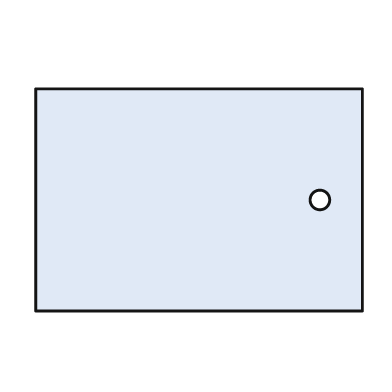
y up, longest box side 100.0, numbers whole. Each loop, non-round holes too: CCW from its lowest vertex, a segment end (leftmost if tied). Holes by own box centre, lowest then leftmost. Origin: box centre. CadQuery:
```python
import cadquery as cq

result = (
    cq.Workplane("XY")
    .moveTo(-50.0, -34.0)
    .lineTo(50.0, -34.0)
    .lineTo(50.0, 34.0)
    .lineTo(-50.0, 34.0)
    .close()
    .moveTo(37.0, 0.0)
    .circle(3.0)
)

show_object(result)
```